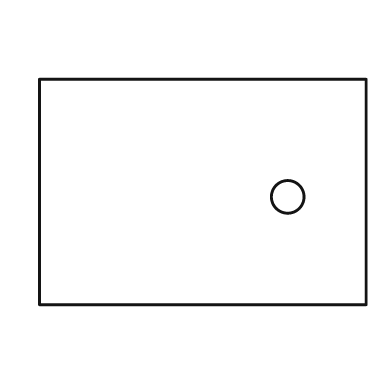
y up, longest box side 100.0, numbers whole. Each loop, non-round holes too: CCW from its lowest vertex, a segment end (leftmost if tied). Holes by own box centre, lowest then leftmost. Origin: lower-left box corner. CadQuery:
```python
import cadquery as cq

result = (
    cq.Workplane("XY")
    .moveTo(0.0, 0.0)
    .lineTo(100.0, 0.0)
    .lineTo(100.0, 69.0)
    .lineTo(0.0, 69.0)
    .close()
    .moveTo(76.0, 33.0)
    .circle(5.0)
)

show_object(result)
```